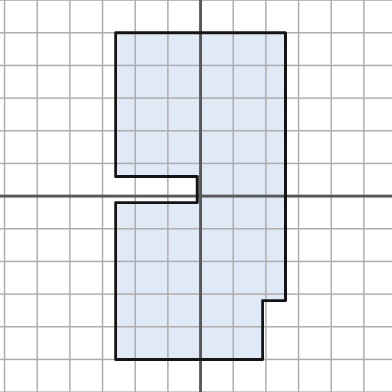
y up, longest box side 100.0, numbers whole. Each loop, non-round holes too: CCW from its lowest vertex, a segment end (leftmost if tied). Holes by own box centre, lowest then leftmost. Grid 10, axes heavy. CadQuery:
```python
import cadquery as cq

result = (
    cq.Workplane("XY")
    .moveTo(-26.0, -50.0)
    .lineTo(19.0, -50.0)
    .lineTo(19.0, -32.0)
    .lineTo(26.0, -32.0)
    .lineTo(26.0, 50.0)
    .lineTo(-26.0, 50.0)
    .lineTo(-26.0, 6.0)
    .lineTo(-1.0, 6.0)
    .lineTo(-1.0, -2.0)
    .lineTo(-26.0, -2.0)
    .close()
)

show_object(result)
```